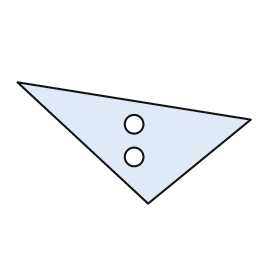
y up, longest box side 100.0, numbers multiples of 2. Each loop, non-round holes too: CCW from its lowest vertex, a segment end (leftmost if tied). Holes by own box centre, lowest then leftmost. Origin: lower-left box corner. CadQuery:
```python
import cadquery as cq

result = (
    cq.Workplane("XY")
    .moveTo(56.0, 0.0)
    .lineTo(100.0, 36.0)
    .lineTo(0.0, 52.0)
    .close()
    .moveTo(50.0, 20.0)
    .circle(4.0)
    .moveTo(50.0, 34.0)
    .circle(4.0)
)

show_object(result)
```